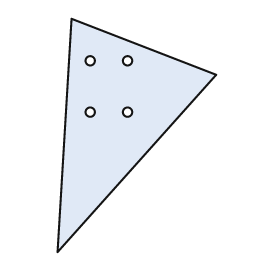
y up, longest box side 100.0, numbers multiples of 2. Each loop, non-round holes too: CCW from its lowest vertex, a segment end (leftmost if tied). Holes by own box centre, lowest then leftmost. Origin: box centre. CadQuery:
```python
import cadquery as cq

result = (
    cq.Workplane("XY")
    .moveTo(-34.0, -50.0)
    .lineTo(34.0, 26.0)
    .lineTo(-28.0, 50.0)
    .close()
    .moveTo(-20.0, 10.0)
    .circle(2.0)
    .moveTo(-4.0, 10.0)
    .circle(2.0)
    .moveTo(-20.0, 32.0)
    .circle(2.0)
    .moveTo(-4.0, 32.0)
    .circle(2.0)
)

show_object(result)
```